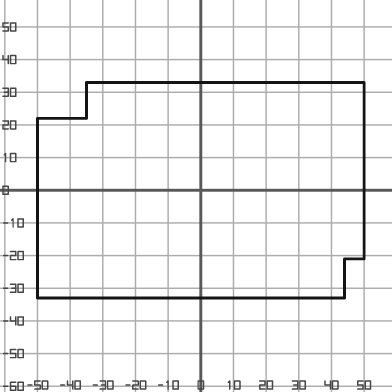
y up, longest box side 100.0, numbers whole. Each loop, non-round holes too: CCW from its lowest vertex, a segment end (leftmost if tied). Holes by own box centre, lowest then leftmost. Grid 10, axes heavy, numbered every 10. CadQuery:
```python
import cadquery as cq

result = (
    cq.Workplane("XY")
    .moveTo(-50.0, -33.0)
    .lineTo(44.0, -33.0)
    .lineTo(44.0, -21.0)
    .lineTo(50.0, -21.0)
    .lineTo(50.0, 33.0)
    .lineTo(-35.0, 33.0)
    .lineTo(-35.0, 22.0)
    .lineTo(-50.0, 22.0)
    .close()
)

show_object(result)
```